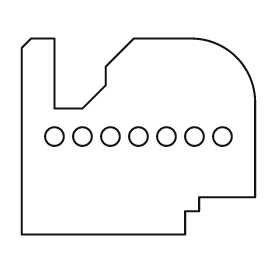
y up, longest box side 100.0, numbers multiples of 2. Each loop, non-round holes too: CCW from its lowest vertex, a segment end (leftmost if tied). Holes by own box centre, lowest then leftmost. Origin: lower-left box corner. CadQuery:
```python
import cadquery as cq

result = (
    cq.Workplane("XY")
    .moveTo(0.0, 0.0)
    .lineTo(70.0, 0.0)
    .lineTo(70.0, 10.0)
    .lineTo(76.0, 10.0)
    .lineTo(76.0, 16.0)
    .lineTo(100.0, 16.0)
    .lineTo(100.0, 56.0)
    .threePointArc((92.0, 76.0), (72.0, 84.0))
    .lineTo(48.0, 84.0)
    .lineTo(36.0, 72.0)
    .lineTo(36.0, 64.0)
    .lineTo(26.0, 54.0)
    .lineTo(14.0, 54.0)
    .lineTo(14.0, 84.0)
    .lineTo(4.0, 84.0)
    .lineTo(0.0, 80.0)
    .close()
    .moveTo(14.0, 42.0)
    .circle(4.0)
    .moveTo(26.0, 42.0)
    .circle(4.0)
    .moveTo(38.0, 42.0)
    .circle(4.0)
    .moveTo(50.0, 42.0)
    .circle(4.0)
    .moveTo(62.0, 42.0)
    .circle(4.0)
    .moveTo(74.0, 42.0)
    .circle(4.0)
    .moveTo(86.0, 42.0)
    .circle(4.0)
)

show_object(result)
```